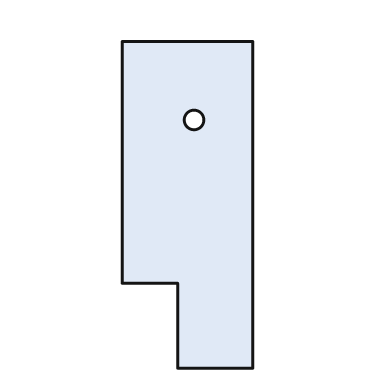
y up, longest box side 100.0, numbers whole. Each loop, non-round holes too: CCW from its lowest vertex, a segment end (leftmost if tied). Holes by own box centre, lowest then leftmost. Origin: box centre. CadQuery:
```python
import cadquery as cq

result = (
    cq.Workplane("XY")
    .moveTo(-3.0, -50.0)
    .lineTo(20.0, -50.0)
    .lineTo(20.0, 50.0)
    .lineTo(-20.0, 50.0)
    .lineTo(-20.0, -24.0)
    .lineTo(-3.0, -24.0)
    .close()
    .moveTo(2.0, 26.0)
    .circle(3.0)
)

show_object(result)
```